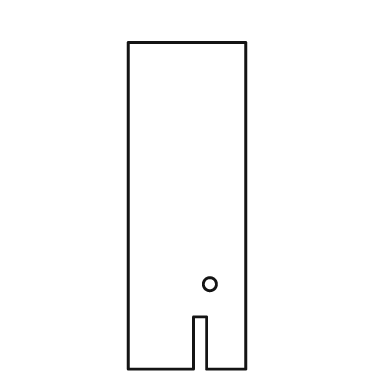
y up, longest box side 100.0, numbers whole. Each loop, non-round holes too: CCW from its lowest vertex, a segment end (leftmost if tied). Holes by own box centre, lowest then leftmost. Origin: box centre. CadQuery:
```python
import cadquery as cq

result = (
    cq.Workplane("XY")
    .moveTo(-18.0, -50.0)
    .lineTo(2.0, -50.0)
    .lineTo(2.0, -34.0)
    .lineTo(6.0, -34.0)
    .lineTo(6.0, -50.0)
    .lineTo(18.0, -50.0)
    .lineTo(18.0, 50.0)
    .lineTo(-18.0, 50.0)
    .close()
    .moveTo(7.0, -24.0)
    .circle(2.0)
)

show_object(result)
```